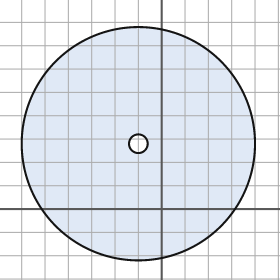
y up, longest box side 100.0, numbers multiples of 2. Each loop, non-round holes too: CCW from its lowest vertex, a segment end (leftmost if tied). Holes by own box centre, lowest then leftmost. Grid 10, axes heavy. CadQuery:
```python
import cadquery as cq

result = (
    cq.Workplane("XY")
    .moveTo(-10.0, 28.0)
    .circle(50.0)
    .moveTo(-10.0, 28.0)
    .circle(4.0)
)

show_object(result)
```